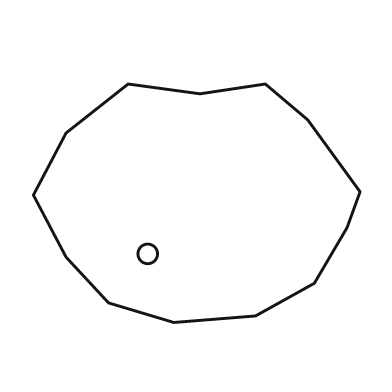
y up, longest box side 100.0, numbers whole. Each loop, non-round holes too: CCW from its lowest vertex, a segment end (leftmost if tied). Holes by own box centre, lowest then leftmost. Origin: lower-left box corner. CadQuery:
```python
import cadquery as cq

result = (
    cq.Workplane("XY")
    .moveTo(43.0, 0.0)
    .lineTo(68.0, 2.0)
    .lineTo(86.0, 12.0)
    .lineTo(96.0, 29.0)
    .lineTo(100.0, 40.0)
    .lineTo(84.0, 62.0)
    .lineTo(71.0, 73.0)
    .lineTo(51.0, 70.0)
    .lineTo(29.0, 73.0)
    .lineTo(10.0, 58.0)
    .lineTo(0.0, 39.0)
    .lineTo(10.0, 20.0)
    .lineTo(23.0, 6.0)
    .close()
    .moveTo(35.0, 21.0)
    .circle(3.0)
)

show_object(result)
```